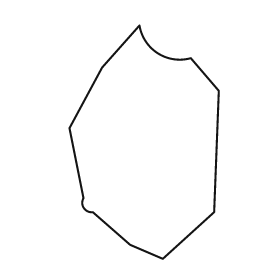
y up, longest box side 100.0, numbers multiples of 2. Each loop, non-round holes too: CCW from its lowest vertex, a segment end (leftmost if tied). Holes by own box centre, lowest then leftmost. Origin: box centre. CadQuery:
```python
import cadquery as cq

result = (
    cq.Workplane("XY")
    .moveTo(8.0, -50.0)
    .lineTo(30.0, -30.0)
    .lineTo(32.0, 22.0)
    .lineTo(20.0, 36.0)
    .threePointArc((6.0, 38.0), (-2.0, 50.0))
    .lineTo(-18.0, 32.0)
    .lineTo(-32.0, 6.0)
    .lineTo(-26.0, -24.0)
    .threePointArc((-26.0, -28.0), (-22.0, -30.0))
    .lineTo(-6.0, -44.0)
    .close()
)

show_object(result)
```